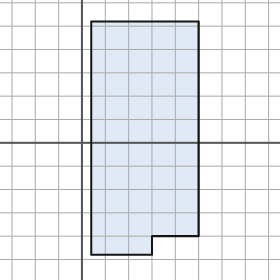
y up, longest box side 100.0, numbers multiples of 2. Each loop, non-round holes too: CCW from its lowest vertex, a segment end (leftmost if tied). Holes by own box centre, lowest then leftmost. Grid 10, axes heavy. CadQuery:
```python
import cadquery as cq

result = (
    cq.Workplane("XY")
    .moveTo(4.0, -48.0)
    .lineTo(30.0, -48.0)
    .lineTo(30.0, -40.0)
    .lineTo(50.0, -40.0)
    .lineTo(50.0, 52.0)
    .lineTo(4.0, 52.0)
    .close()
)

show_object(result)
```